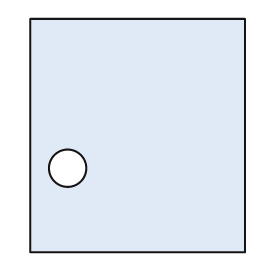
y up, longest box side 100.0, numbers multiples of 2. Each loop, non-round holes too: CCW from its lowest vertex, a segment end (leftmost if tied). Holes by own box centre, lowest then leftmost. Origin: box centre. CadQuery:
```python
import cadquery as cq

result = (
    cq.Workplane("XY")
    .moveTo(-46.0, -50.0)
    .lineTo(46.0, -50.0)
    .lineTo(46.0, 50.0)
    .lineTo(-46.0, 50.0)
    .close()
    .moveTo(-30.0, -14.0)
    .circle(8.0)
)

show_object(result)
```